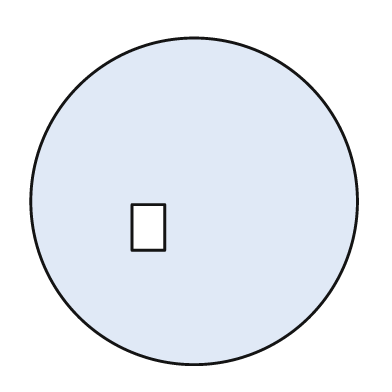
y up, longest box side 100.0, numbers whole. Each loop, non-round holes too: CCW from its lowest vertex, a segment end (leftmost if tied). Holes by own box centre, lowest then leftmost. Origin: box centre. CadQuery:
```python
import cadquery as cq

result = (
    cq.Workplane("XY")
    .moveTo(0.0, 0.0)
    .circle(50.0)
    .moveTo(-19.0, -15.0)
    .lineTo(-9.0, -15.0)
    .lineTo(-9.0, -1.0)
    .lineTo(-19.0, -1.0)
    .close()
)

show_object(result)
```